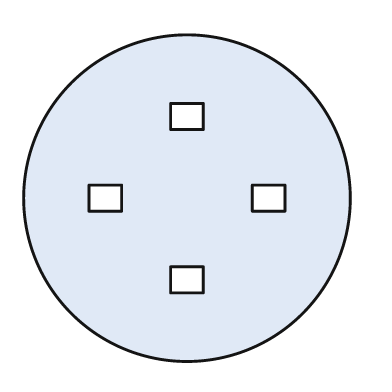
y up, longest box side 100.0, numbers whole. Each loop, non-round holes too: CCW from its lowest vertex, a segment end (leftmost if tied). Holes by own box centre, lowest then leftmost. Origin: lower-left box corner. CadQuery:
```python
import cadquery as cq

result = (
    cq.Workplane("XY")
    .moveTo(50.0, 50.0)
    .circle(50.0)
    .moveTo(45.0, 21.0)
    .lineTo(55.0, 21.0)
    .lineTo(55.0, 29.0)
    .lineTo(45.0, 29.0)
    .close()
    .moveTo(20.0, 46.0)
    .lineTo(30.0, 46.0)
    .lineTo(30.0, 54.0)
    .lineTo(20.0, 54.0)
    .close()
    .moveTo(70.0, 46.0)
    .lineTo(80.0, 46.0)
    .lineTo(80.0, 54.0)
    .lineTo(70.0, 54.0)
    .close()
    .moveTo(45.0, 71.0)
    .lineTo(55.0, 71.0)
    .lineTo(55.0, 79.0)
    .lineTo(45.0, 79.0)
    .close()
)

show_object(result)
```